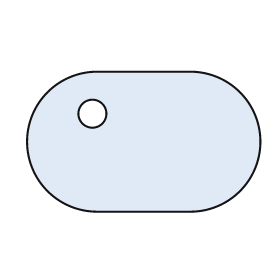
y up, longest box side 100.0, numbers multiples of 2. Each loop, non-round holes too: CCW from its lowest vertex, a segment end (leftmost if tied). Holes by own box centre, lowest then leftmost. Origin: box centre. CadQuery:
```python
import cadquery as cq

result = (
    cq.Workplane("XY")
    .moveTo(-20.0, -30.0)
    .lineTo(20.0, -30.0)
    .threePointArc((50.0, 0.0), (20.0, 30.0))
    .lineTo(-20.0, 30.0)
    .threePointArc((-50.0, 0.0), (-20.0, -30.0))
    .close()
    .moveTo(-22.0, 12.0)
    .circle(6.0)
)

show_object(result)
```